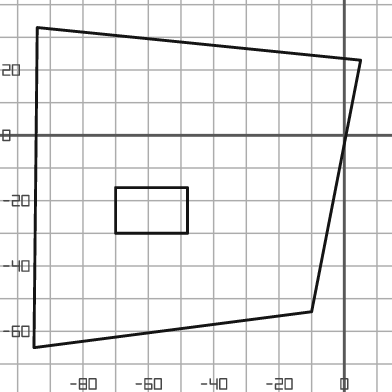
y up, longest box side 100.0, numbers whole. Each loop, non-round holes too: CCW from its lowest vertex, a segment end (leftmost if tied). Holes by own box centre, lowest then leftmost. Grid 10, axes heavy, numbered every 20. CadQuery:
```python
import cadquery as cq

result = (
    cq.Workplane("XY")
    .moveTo(-95.0, -65.0)
    .lineTo(-10.0, -54.0)
    .lineTo(5.0, 23.0)
    .lineTo(-94.0, 33.0)
    .close()
    .moveTo(-70.0, -30.0)
    .lineTo(-48.0, -30.0)
    .lineTo(-48.0, -16.0)
    .lineTo(-70.0, -16.0)
    .close()
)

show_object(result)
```